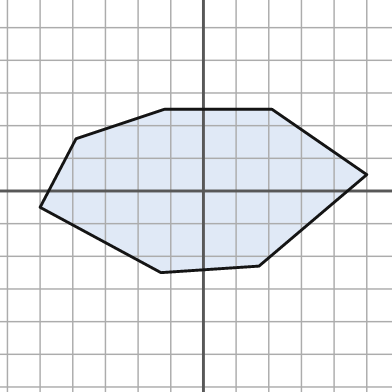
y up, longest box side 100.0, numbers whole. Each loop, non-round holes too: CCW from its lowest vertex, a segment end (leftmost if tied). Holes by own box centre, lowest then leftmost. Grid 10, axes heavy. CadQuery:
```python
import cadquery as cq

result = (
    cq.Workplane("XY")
    .moveTo(-13.0, -25.0)
    .lineTo(17.0, -23.0)
    .lineTo(50.0, 5.0)
    .lineTo(21.0, 25.0)
    .lineTo(-12.0, 25.0)
    .lineTo(-39.0, 16.0)
    .lineTo(-50.0, -5.0)
    .close()
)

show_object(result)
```